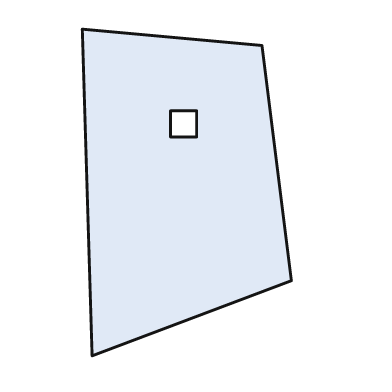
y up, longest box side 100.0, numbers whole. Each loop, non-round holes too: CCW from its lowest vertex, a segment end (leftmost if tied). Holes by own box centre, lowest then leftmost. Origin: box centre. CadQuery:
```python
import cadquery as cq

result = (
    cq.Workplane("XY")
    .moveTo(-29.0, -50.0)
    .lineTo(32.0, -27.0)
    .lineTo(23.0, 45.0)
    .lineTo(-32.0, 50.0)
    .close()
    .moveTo(-5.0, 17.0)
    .lineTo(3.0, 17.0)
    .lineTo(3.0, 25.0)
    .lineTo(-5.0, 25.0)
    .close()
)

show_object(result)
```